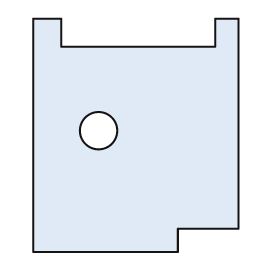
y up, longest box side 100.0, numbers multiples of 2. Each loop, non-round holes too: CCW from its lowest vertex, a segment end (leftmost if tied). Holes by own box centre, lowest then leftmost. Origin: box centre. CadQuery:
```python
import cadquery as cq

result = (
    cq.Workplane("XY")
    .moveTo(-44.0, -50.0)
    .lineTo(18.0, -50.0)
    .lineTo(18.0, -40.0)
    .lineTo(44.0, -40.0)
    .lineTo(44.0, 50.0)
    .lineTo(34.0, 50.0)
    .lineTo(34.0, 38.0)
    .lineTo(-32.0, 38.0)
    .lineTo(-32.0, 50.0)
    .lineTo(-44.0, 50.0)
    .close()
    .moveTo(-16.0, 2.0)
    .circle(8.0)
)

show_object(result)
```